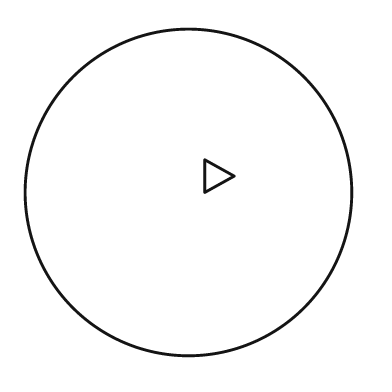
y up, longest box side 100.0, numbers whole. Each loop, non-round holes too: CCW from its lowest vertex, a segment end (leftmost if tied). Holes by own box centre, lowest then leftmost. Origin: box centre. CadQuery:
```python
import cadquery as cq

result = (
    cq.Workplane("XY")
    .moveTo(0.0, 0.0)
    .circle(50.0)
    .moveTo(5.0, 0.0)
    .lineTo(14.0, 5.0)
    .lineTo(5.0, 10.0)
    .close()
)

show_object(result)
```